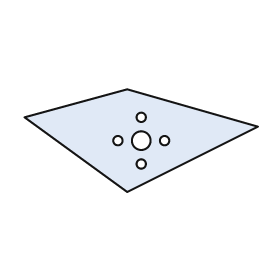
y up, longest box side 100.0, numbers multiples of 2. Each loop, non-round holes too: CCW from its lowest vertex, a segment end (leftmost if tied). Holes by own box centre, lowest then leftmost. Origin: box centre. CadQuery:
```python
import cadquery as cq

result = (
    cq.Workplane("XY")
    .moveTo(-6.0, -22.0)
    .lineTo(50.0, 6.0)
    .lineTo(-6.0, 22.0)
    .lineTo(-50.0, 10.0)
    .close()
    .moveTo(0.0, -10.0)
    .circle(2.0)
    .moveTo(-10.0, 0.0)
    .circle(2.0)
    .moveTo(0.0, 0.0)
    .circle(4.0)
    .moveTo(10.0, 0.0)
    .circle(2.0)
    .moveTo(0.0, 10.0)
    .circle(2.0)
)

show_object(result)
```